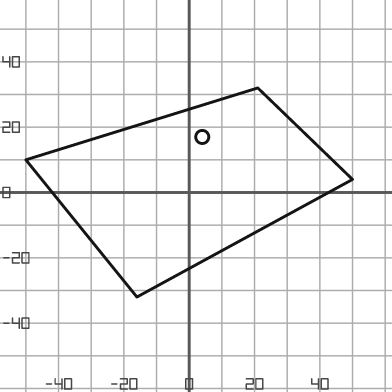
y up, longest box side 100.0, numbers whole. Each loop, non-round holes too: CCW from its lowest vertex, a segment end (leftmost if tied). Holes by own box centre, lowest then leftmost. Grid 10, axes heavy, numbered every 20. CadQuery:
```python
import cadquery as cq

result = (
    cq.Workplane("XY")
    .moveTo(-16.0, -32.0)
    .lineTo(50.0, 4.0)
    .lineTo(21.0, 32.0)
    .lineTo(-50.0, 10.0)
    .close()
    .moveTo(4.0, 17.0)
    .circle(2.0)
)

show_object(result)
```